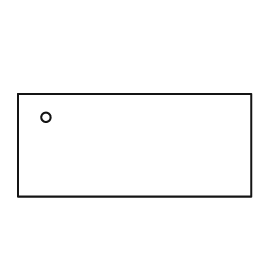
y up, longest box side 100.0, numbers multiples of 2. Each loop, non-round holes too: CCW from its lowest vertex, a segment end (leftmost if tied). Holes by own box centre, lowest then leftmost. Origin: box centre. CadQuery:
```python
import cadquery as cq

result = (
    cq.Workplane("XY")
    .moveTo(-50.0, -22.0)
    .lineTo(50.0, -22.0)
    .lineTo(50.0, 22.0)
    .lineTo(-50.0, 22.0)
    .close()
    .moveTo(-38.0, 12.0)
    .circle(2.0)
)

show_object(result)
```